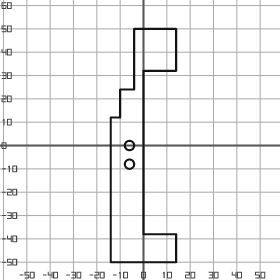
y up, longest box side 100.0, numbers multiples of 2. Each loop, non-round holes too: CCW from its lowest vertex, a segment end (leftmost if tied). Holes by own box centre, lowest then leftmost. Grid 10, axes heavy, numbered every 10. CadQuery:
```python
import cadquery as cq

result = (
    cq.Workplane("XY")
    .moveTo(-14.0, -50.0)
    .lineTo(14.0, -50.0)
    .lineTo(14.0, -38.0)
    .lineTo(0.0, -38.0)
    .lineTo(0.0, 32.0)
    .lineTo(14.0, 32.0)
    .lineTo(14.0, 50.0)
    .lineTo(-4.0, 50.0)
    .lineTo(-4.0, 24.0)
    .lineTo(-10.0, 24.0)
    .lineTo(-10.0, 12.0)
    .lineTo(-14.0, 12.0)
    .close()
    .moveTo(-6.0, -8.0)
    .circle(2.0)
    .moveTo(-6.0, 0.0)
    .circle(2.0)
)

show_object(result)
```